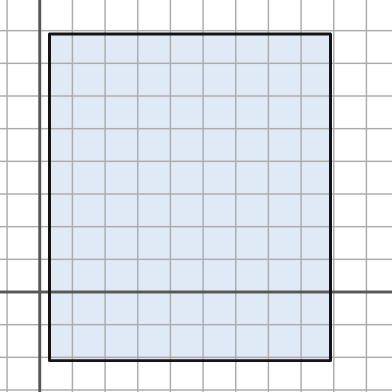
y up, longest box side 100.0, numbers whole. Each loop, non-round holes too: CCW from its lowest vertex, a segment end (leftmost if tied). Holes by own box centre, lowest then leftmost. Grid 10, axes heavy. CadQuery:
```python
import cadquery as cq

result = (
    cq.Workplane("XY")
    .moveTo(3.0, -21.0)
    .lineTo(89.0, -21.0)
    .lineTo(89.0, 79.0)
    .lineTo(3.0, 79.0)
    .close()
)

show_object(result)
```